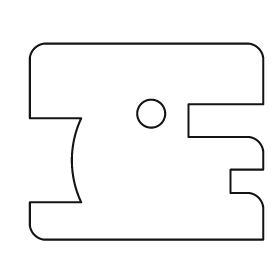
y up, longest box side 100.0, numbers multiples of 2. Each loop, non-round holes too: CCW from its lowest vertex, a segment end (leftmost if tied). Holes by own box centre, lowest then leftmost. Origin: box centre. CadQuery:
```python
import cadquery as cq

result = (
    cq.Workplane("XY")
    .moveTo(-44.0, -42.0)
    .lineTo(50.0, -42.0)
    .lineTo(50.0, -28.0)
    .threePointArc((48.0, -24.0), (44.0, -22.0))
    .lineTo(36.0, -22.0)
    .lineTo(36.0, -12.0)
    .lineTo(50.0, -12.0)
    .lineTo(50.0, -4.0)
    .threePointArc((48.0, 0.0), (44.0, 2.0))
    .lineTo(18.0, 2.0)
    .lineTo(18.0, 16.0)
    .lineTo(50.0, 16.0)
    .lineTo(50.0, 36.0)
    .threePointArc((48.0, 40.0), (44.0, 42.0))
    .lineTo(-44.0, 42.0)
    .threePointArc((-48.0, 40.0), (-50.0, 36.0))
    .lineTo(-50.0, 10.0)
    .lineTo(-28.0, 10.0)
    .threePointArc((-32.0, -8.0), (-28.0, -26.0))
    .lineTo(-50.0, -26.0)
    .lineTo(-50.0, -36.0)
    .threePointArc((-48.0, -40.0), (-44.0, -42.0))
    .close()
    .moveTo(2.0, 12.0)
    .circle(6.0)
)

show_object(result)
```